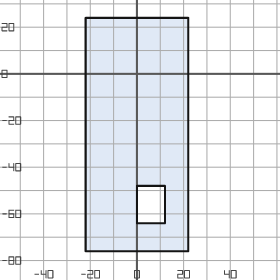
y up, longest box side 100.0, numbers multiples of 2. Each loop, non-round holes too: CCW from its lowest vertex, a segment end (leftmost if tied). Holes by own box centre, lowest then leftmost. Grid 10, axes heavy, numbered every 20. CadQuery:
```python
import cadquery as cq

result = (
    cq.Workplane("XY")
    .moveTo(-22.0, -76.0)
    .lineTo(22.0, -76.0)
    .lineTo(22.0, 24.0)
    .lineTo(-22.0, 24.0)
    .close()
    .moveTo(0.0, -64.0)
    .lineTo(12.0, -64.0)
    .lineTo(12.0, -48.0)
    .lineTo(0.0, -48.0)
    .close()
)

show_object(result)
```